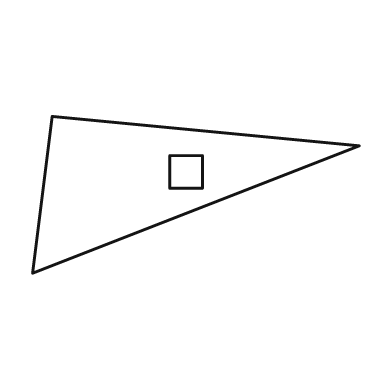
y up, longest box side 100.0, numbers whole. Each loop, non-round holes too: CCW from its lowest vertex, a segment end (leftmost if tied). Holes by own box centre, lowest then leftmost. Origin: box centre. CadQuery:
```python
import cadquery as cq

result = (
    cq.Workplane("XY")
    .moveTo(-50.0, -24.0)
    .lineTo(50.0, 15.0)
    .lineTo(-44.0, 24.0)
    .close()
    .moveTo(-8.0, 2.0)
    .lineTo(2.0, 2.0)
    .lineTo(2.0, 12.0)
    .lineTo(-8.0, 12.0)
    .close()
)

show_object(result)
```